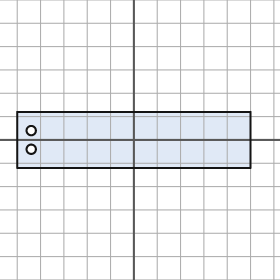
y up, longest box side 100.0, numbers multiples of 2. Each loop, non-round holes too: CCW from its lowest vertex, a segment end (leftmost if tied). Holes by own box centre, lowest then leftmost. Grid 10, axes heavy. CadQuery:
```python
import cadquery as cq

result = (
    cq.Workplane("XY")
    .moveTo(-50.0, -12.0)
    .lineTo(50.0, -12.0)
    .lineTo(50.0, 12.0)
    .lineTo(-50.0, 12.0)
    .close()
    .moveTo(-44.0, -4.0)
    .circle(2.0)
    .moveTo(-44.0, 4.0)
    .circle(2.0)
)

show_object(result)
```